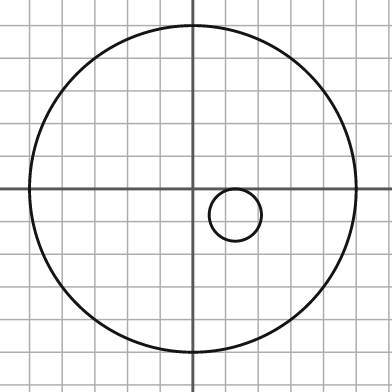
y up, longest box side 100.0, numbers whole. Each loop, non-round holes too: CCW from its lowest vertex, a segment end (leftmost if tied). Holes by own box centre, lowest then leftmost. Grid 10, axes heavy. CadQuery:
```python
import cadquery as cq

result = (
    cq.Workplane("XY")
    .moveTo(0.0, 0.0)
    .circle(50.0)
    .moveTo(13.0, -8.0)
    .circle(8.0)
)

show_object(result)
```